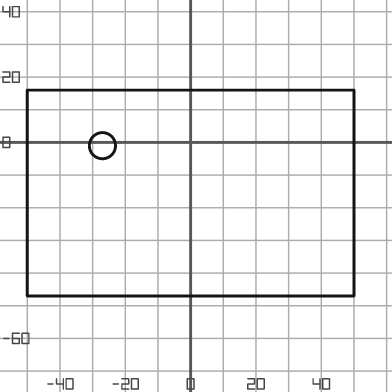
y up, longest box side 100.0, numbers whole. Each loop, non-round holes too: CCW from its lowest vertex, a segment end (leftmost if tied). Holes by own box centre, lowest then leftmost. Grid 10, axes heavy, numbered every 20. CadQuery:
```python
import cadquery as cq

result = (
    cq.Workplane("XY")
    .moveTo(-50.0, -47.0)
    .lineTo(50.0, -47.0)
    .lineTo(50.0, 16.0)
    .lineTo(-50.0, 16.0)
    .close()
    .moveTo(-27.0, -1.0)
    .circle(4.0)
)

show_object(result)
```